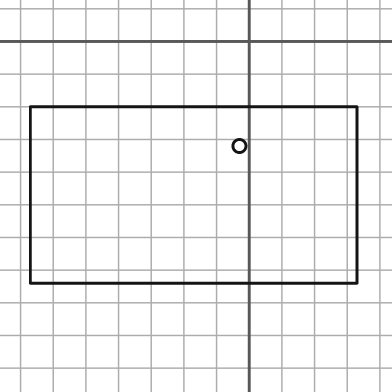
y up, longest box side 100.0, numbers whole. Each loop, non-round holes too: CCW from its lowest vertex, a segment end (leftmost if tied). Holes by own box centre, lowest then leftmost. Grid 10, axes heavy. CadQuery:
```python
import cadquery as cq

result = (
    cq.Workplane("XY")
    .moveTo(-67.0, -74.0)
    .lineTo(33.0, -74.0)
    .lineTo(33.0, -20.0)
    .lineTo(-67.0, -20.0)
    .close()
    .moveTo(-3.0, -32.0)
    .circle(2.0)
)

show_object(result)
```